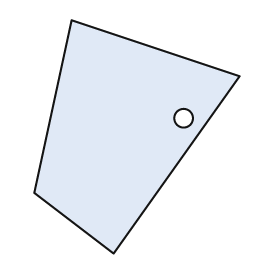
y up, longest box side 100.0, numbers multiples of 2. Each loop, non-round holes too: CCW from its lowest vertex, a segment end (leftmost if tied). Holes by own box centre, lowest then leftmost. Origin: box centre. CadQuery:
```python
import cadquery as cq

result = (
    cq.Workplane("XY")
    .moveTo(-10.0, -50.0)
    .lineTo(44.0, 26.0)
    .lineTo(-28.0, 50.0)
    .lineTo(-44.0, -24.0)
    .close()
    .moveTo(20.0, 8.0)
    .circle(4.0)
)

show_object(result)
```